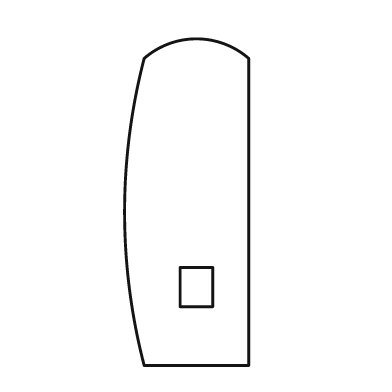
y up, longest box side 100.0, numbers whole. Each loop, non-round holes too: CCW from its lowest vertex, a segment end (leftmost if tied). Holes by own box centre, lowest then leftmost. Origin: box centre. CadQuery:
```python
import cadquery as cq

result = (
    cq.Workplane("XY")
    .moveTo(-13.0, -50.0)
    .lineTo(19.0, -50.0)
    .lineTo(19.0, 44.0)
    .threePointArc((3.0, 50.0), (-13.0, 44.0))
    .threePointArc((-19.0, -3.0), (-13.0, -50.0))
    .close()
    .moveTo(-2.0, -32.0)
    .lineTo(8.0, -32.0)
    .lineTo(8.0, -20.0)
    .lineTo(-2.0, -20.0)
    .close()
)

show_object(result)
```